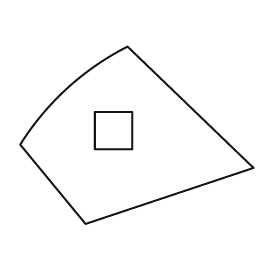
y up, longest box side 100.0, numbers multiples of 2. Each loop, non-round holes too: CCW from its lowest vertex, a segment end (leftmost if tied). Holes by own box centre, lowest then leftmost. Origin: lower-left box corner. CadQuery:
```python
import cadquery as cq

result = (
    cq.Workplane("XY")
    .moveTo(28.0, 0.0)
    .lineTo(100.0, 24.0)
    .lineTo(46.0, 76.0)
    .threePointArc((20.0, 58.0), (0.0, 34.0))
    .close()
    .moveTo(32.0, 32.0)
    .lineTo(48.0, 32.0)
    .lineTo(48.0, 48.0)
    .lineTo(32.0, 48.0)
    .close()
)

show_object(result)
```